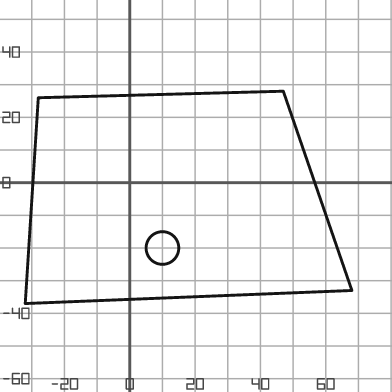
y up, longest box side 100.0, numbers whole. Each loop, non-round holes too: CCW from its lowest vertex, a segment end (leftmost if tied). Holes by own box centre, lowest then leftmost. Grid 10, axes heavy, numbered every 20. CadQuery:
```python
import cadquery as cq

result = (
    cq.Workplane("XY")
    .moveTo(-32.0, -37.0)
    .lineTo(68.0, -33.0)
    .lineTo(47.0, 28.0)
    .lineTo(-28.0, 26.0)
    .close()
    .moveTo(10.0, -20.0)
    .circle(5.0)
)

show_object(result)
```